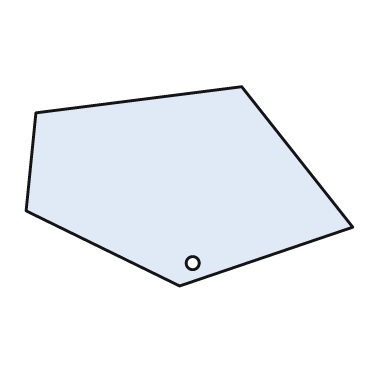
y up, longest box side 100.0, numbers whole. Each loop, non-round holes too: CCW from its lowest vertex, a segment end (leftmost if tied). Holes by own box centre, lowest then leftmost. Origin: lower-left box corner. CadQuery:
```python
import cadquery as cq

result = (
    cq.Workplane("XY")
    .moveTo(47.0, 0.0)
    .lineTo(100.0, 18.0)
    .lineTo(66.0, 61.0)
    .lineTo(3.0, 53.0)
    .lineTo(0.0, 23.0)
    .close()
    .moveTo(51.0, 7.0)
    .circle(2.0)
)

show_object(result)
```